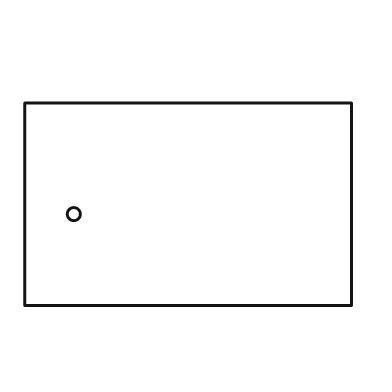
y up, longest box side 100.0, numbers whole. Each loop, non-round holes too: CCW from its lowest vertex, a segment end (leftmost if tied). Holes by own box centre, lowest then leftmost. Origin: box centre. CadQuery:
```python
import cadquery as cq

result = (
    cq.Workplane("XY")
    .moveTo(-50.0, -31.0)
    .lineTo(50.0, -31.0)
    .lineTo(50.0, 31.0)
    .lineTo(-50.0, 31.0)
    .close()
    .moveTo(-35.0, -3.0)
    .circle(2.0)
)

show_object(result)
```